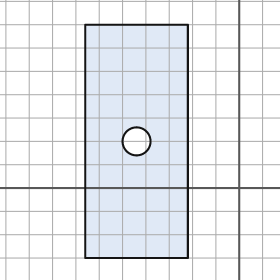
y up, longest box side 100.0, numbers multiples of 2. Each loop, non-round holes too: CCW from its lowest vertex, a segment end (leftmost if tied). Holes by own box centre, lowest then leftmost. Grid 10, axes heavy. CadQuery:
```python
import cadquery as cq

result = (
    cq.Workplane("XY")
    .moveTo(-66.0, -30.0)
    .lineTo(-22.0, -30.0)
    .lineTo(-22.0, 70.0)
    .lineTo(-66.0, 70.0)
    .close()
    .moveTo(-44.0, 20.0)
    .circle(6.0)
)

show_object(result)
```